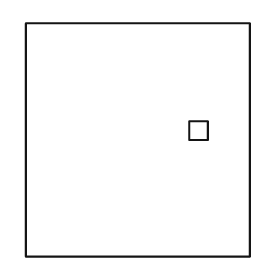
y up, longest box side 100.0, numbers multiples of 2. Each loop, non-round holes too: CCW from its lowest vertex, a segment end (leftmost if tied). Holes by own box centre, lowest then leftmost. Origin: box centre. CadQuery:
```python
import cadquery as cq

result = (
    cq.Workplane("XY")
    .moveTo(-48.0, -50.0)
    .lineTo(48.0, -50.0)
    .lineTo(48.0, 50.0)
    .lineTo(-48.0, 50.0)
    .close()
    .moveTo(22.0, 0.0)
    .lineTo(30.0, 0.0)
    .lineTo(30.0, 8.0)
    .lineTo(22.0, 8.0)
    .close()
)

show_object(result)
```